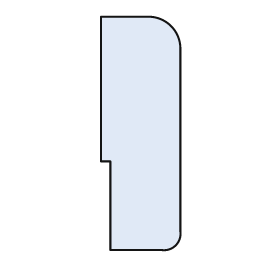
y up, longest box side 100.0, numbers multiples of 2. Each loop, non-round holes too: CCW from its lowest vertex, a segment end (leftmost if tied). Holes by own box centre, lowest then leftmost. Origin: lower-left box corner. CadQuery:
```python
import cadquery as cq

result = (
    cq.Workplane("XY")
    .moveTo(4.0, 0.0)
    .lineTo(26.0, 0.0)
    .threePointArc((32.0, 2.0), (34.0, 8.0))
    .lineTo(34.0, 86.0)
    .threePointArc((30.0, 96.0), (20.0, 100.0))
    .lineTo(0.0, 100.0)
    .lineTo(0.0, 38.0)
    .lineTo(4.0, 38.0)
    .close()
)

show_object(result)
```